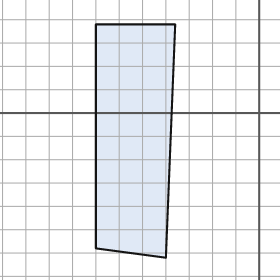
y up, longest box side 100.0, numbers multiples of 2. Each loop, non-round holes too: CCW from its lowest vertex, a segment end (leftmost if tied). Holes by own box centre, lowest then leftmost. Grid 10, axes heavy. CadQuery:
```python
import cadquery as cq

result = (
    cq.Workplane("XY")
    .moveTo(-40.0, -62.0)
    .lineTo(-36.0, 38.0)
    .lineTo(-70.0, 38.0)
    .lineTo(-70.0, -58.0)
    .close()
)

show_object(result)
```